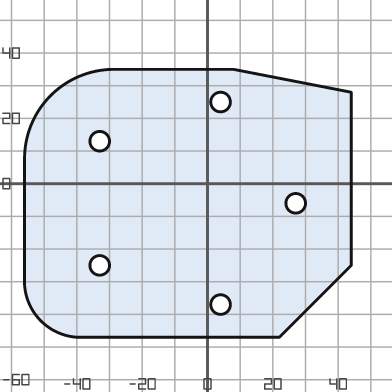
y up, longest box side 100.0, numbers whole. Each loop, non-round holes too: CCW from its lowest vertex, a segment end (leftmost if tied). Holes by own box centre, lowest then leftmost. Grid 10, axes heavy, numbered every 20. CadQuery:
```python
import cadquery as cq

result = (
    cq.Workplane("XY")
    .moveTo(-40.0, -47.0)
    .lineTo(22.0, -47.0)
    .lineTo(44.0, -25.0)
    .lineTo(44.0, 28.0)
    .lineTo(8.0, 35.0)
    .lineTo(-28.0, 35.0)
    .threePointArc((-48.0, 27.0), (-56.0, 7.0))
    .lineTo(-56.0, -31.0)
    .threePointArc((-51.0, -42.0), (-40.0, -47.0))
    .close()
    .moveTo(4.0, -37.0)
    .circle(3.0)
    .moveTo(-33.0, -25.0)
    .circle(3.0)
    .moveTo(27.0, -6.0)
    .circle(3.0)
    .moveTo(-33.0, 13.0)
    .circle(3.0)
    .moveTo(4.0, 25.0)
    .circle(3.0)
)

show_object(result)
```